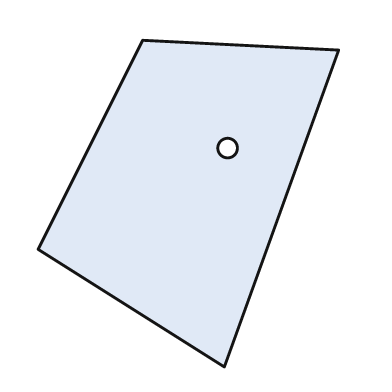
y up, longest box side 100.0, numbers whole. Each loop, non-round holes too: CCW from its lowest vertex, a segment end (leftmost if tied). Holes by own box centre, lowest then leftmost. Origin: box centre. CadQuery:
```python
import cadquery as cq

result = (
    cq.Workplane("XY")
    .moveTo(11.0, -50.0)
    .lineTo(46.0, 47.0)
    .lineTo(-14.0, 50.0)
    .lineTo(-46.0, -14.0)
    .close()
    .moveTo(12.0, 17.0)
    .circle(3.0)
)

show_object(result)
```